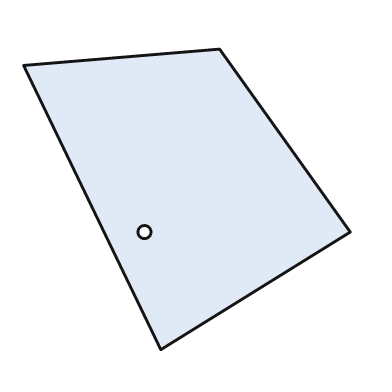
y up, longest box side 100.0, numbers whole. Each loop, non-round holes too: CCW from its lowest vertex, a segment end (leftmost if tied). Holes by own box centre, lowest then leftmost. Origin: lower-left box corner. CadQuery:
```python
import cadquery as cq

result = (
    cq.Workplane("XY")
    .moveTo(42.0, 0.0)
    .lineTo(100.0, 36.0)
    .lineTo(60.0, 92.0)
    .lineTo(0.0, 87.0)
    .close()
    .moveTo(37.0, 36.0)
    .circle(2.0)
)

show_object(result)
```